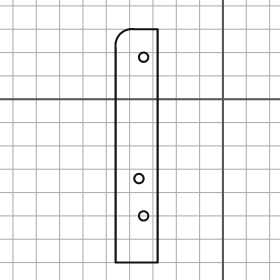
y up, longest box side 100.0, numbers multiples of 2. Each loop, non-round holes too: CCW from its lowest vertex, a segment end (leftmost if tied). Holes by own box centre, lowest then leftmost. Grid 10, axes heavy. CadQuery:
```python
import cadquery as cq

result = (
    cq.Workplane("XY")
    .moveTo(-46.0, -70.0)
    .lineTo(-28.0, -70.0)
    .lineTo(-28.0, 30.0)
    .lineTo(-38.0, 30.0)
    .threePointArc((-44.0, 28.0), (-46.0, 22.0))
    .close()
    .moveTo(-34.0, -50.0)
    .circle(2.0)
    .moveTo(-36.0, -34.0)
    .circle(2.0)
    .moveTo(-34.0, 18.0)
    .circle(2.0)
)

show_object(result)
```